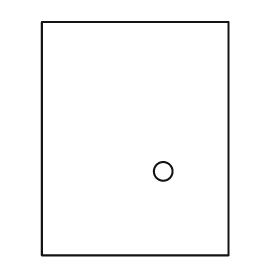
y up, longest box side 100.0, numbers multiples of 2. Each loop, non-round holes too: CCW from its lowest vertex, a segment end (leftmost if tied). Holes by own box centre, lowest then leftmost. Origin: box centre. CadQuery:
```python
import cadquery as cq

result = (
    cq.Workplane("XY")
    .moveTo(-40.0, -50.0)
    .lineTo(40.0, -50.0)
    .lineTo(40.0, 50.0)
    .lineTo(-40.0, 50.0)
    .close()
    .moveTo(12.0, -14.0)
    .circle(4.0)
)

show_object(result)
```